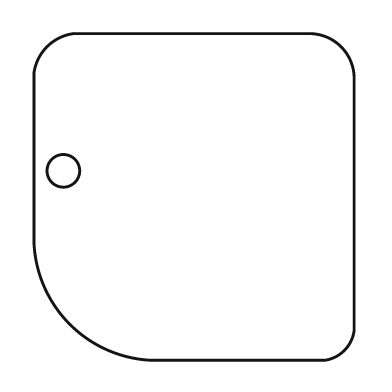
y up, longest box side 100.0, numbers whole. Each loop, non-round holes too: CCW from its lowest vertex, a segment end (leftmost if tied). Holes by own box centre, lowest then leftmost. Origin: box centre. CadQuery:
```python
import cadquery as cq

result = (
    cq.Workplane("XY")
    .moveTo(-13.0, -50.0)
    .lineTo(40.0, -50.0)
    .threePointArc((46.0, -47.0), (49.0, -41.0))
    .lineTo(49.0, 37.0)
    .threePointArc((45.0, 46.0), (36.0, 50.0))
    .lineTo(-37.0, 50.0)
    .threePointArc((-45.0, 46.0), (-49.0, 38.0))
    .lineTo(-49.0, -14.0)
    .threePointArc((-38.0, -39.0), (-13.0, -50.0))
    .close()
    .moveTo(-40.0, 8.0)
    .circle(5.0)
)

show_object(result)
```